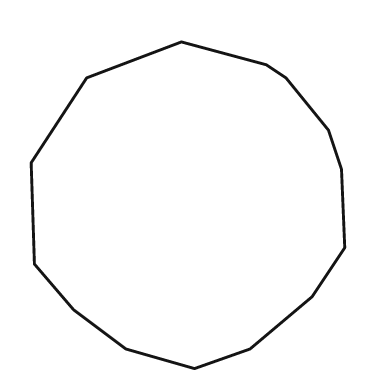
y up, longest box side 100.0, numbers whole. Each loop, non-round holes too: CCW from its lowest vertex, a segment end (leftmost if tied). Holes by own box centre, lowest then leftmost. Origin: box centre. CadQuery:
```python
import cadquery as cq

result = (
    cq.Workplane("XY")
    .moveTo(2.0, -50.0)
    .lineTo(19.0, -44.0)
    .lineTo(38.0, -28.0)
    .lineTo(48.0, -13.0)
    .lineTo(47.0, 11.0)
    .lineTo(43.0, 23.0)
    .lineTo(30.0, 39.0)
    .lineTo(24.0, 43.0)
    .lineTo(-2.0, 50.0)
    .lineTo(-31.0, 39.0)
    .lineTo(-48.0, 13.0)
    .lineTo(-47.0, -18.0)
    .lineTo(-35.0, -32.0)
    .lineTo(-19.0, -44.0)
    .close()
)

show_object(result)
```